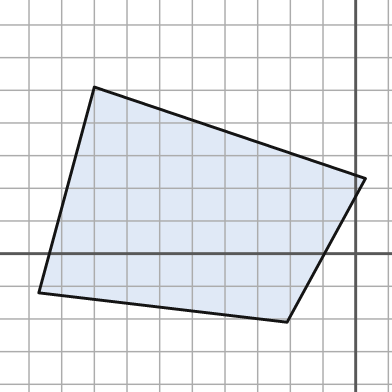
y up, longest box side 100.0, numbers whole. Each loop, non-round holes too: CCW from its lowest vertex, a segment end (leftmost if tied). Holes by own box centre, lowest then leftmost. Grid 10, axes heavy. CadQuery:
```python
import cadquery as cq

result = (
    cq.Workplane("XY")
    .moveTo(-21.0, -21.0)
    .lineTo(3.0, 23.0)
    .lineTo(-80.0, 51.0)
    .lineTo(-97.0, -12.0)
    .close()
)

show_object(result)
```